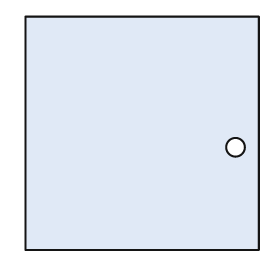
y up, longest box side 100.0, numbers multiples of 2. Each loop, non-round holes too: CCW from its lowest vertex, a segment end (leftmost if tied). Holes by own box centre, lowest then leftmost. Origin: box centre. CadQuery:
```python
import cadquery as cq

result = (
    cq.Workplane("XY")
    .moveTo(-50.0, -50.0)
    .lineTo(50.0, -50.0)
    .lineTo(50.0, 50.0)
    .lineTo(-50.0, 50.0)
    .close()
    .moveTo(40.0, -6.0)
    .circle(4.0)
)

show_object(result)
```